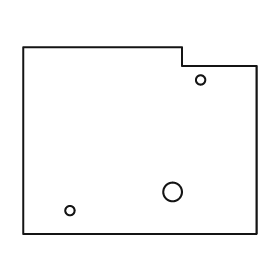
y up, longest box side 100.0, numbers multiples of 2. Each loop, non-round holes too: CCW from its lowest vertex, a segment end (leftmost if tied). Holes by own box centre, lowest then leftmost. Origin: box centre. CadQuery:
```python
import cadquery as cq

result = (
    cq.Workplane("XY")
    .moveTo(-50.0, -40.0)
    .lineTo(50.0, -40.0)
    .lineTo(50.0, 32.0)
    .lineTo(18.0, 32.0)
    .lineTo(18.0, 40.0)
    .lineTo(-50.0, 40.0)
    .close()
    .moveTo(-30.0, -30.0)
    .circle(2.0)
    .moveTo(14.0, -22.0)
    .circle(4.0)
    .moveTo(26.0, 26.0)
    .circle(2.0)
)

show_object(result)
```